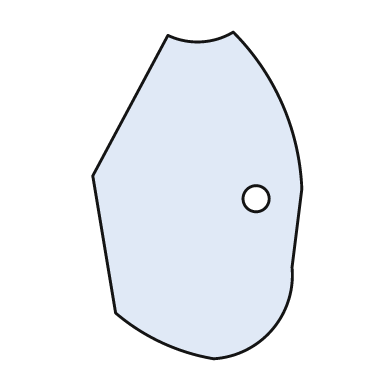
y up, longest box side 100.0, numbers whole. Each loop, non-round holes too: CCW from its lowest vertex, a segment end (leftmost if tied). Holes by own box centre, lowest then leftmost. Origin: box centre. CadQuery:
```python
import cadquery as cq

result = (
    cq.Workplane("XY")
    .moveTo(5.0, -50.0)
    .threePointArc((23.0, -41.0), (29.0, -22.0))
    .lineTo(32.0, 2.0)
    .threePointArc((26.0, 28.0), (11.0, 50.0))
    .threePointArc((1.0, 47.0), (-9.0, 49.0))
    .lineTo(-32.0, 6.0)
    .lineTo(-25.0, -36.0)
    .threePointArc((-11.0, -45.0), (5.0, -50.0))
    .close()
    .moveTo(18.0, -1.0)
    .circle(4.0)
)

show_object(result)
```